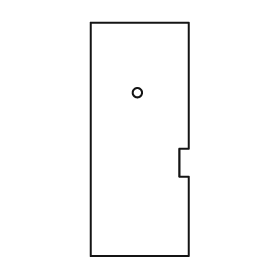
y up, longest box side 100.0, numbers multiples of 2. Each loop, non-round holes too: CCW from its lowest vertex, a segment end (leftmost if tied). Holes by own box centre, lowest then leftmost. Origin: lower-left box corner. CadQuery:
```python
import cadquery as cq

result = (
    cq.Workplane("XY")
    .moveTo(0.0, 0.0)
    .lineTo(42.0, 0.0)
    .lineTo(42.0, 34.0)
    .lineTo(38.0, 34.0)
    .lineTo(38.0, 46.0)
    .lineTo(42.0, 46.0)
    .lineTo(42.0, 100.0)
    .lineTo(0.0, 100.0)
    .close()
    .moveTo(20.0, 70.0)
    .circle(2.0)
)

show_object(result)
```